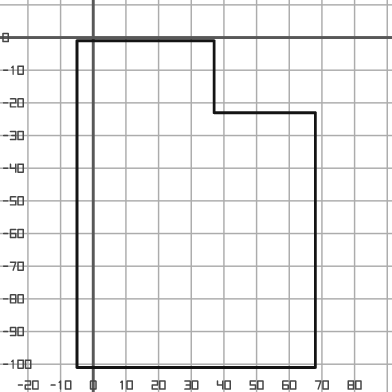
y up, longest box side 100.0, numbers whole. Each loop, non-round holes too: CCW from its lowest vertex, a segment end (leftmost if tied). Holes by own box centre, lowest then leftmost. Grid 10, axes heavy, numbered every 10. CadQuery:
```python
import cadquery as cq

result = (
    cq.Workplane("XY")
    .moveTo(-5.0, -101.0)
    .lineTo(68.0, -101.0)
    .lineTo(68.0, -23.0)
    .lineTo(37.0, -23.0)
    .lineTo(37.0, -1.0)
    .lineTo(-5.0, -1.0)
    .close()
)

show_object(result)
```